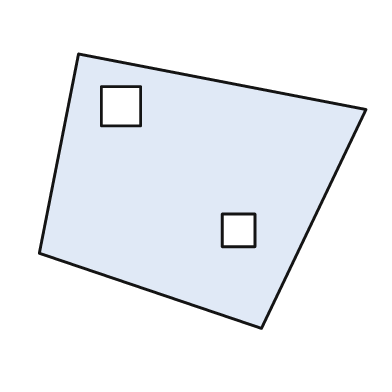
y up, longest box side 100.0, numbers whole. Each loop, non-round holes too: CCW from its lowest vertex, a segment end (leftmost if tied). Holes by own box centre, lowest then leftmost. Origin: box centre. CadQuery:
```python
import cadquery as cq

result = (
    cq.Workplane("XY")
    .moveTo(18.0, -42.0)
    .lineTo(50.0, 25.0)
    .lineTo(-38.0, 42.0)
    .lineTo(-50.0, -19.0)
    .close()
    .moveTo(6.0, -17.0)
    .lineTo(16.0, -17.0)
    .lineTo(16.0, -7.0)
    .lineTo(6.0, -7.0)
    .close()
    .moveTo(-31.0, 20.0)
    .lineTo(-19.0, 20.0)
    .lineTo(-19.0, 32.0)
    .lineTo(-31.0, 32.0)
    .close()
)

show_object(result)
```